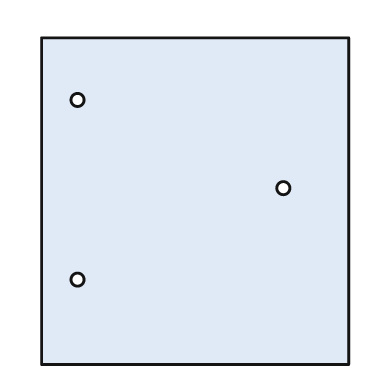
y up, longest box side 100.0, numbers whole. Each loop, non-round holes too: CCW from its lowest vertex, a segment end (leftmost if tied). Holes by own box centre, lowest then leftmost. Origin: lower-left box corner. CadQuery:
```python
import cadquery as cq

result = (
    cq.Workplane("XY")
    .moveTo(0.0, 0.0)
    .lineTo(94.0, 0.0)
    .lineTo(94.0, 100.0)
    .lineTo(0.0, 100.0)
    .close()
    .moveTo(11.0, 26.0)
    .circle(2.0)
    .moveTo(74.0, 54.0)
    .circle(2.0)
    .moveTo(11.0, 81.0)
    .circle(2.0)
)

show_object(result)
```